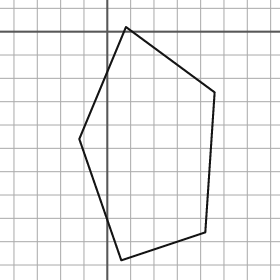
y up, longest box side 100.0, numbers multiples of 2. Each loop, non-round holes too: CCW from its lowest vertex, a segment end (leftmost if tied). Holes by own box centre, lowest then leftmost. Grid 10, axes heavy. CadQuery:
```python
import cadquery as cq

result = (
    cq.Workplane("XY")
    .moveTo(6.0, -98.0)
    .lineTo(42.0, -86.0)
    .lineTo(46.0, -26.0)
    .lineTo(8.0, 2.0)
    .lineTo(-12.0, -46.0)
    .close()
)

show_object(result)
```